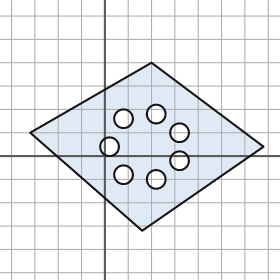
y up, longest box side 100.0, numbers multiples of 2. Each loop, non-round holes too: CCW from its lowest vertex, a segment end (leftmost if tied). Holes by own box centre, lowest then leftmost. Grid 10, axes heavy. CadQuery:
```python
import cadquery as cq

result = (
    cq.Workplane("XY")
    .moveTo(16.0, -32.0)
    .lineTo(68.0, 4.0)
    .lineTo(20.0, 40.0)
    .lineTo(-32.0, 10.0)
    .close()
    .moveTo(22.0, -10.0)
    .circle(4.0)
    .moveTo(8.0, -8.0)
    .circle(4.0)
    .moveTo(32.0, -2.0)
    .circle(4.0)
    .moveTo(2.0, 4.0)
    .circle(4.0)
    .moveTo(32.0, 10.0)
    .circle(4.0)
    .moveTo(8.0, 16.0)
    .circle(4.0)
    .moveTo(22.0, 18.0)
    .circle(4.0)
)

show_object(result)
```